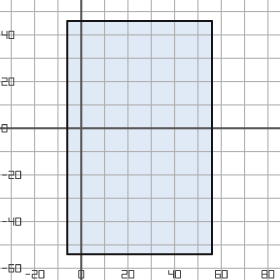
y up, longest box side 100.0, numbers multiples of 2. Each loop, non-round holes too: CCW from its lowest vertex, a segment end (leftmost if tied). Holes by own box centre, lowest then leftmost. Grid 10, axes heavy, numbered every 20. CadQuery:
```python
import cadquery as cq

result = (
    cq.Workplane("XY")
    .moveTo(-6.0, -54.0)
    .lineTo(56.0, -54.0)
    .lineTo(56.0, 46.0)
    .lineTo(-6.0, 46.0)
    .close()
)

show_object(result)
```